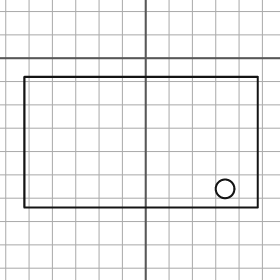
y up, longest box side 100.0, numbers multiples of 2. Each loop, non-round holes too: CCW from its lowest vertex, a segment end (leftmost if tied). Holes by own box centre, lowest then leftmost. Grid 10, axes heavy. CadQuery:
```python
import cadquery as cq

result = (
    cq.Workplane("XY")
    .moveTo(-52.0, -64.0)
    .lineTo(48.0, -64.0)
    .lineTo(48.0, -8.0)
    .lineTo(-52.0, -8.0)
    .close()
    .moveTo(34.0, -56.0)
    .circle(4.0)
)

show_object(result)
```